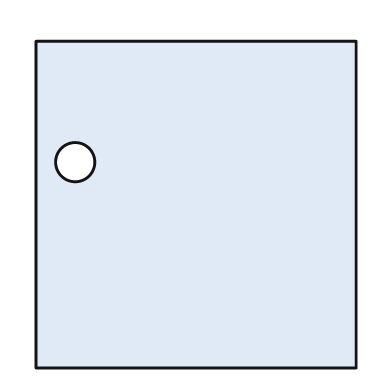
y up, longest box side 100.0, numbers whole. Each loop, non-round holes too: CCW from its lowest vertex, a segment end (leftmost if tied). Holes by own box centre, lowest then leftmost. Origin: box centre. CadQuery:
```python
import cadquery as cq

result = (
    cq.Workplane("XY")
    .moveTo(-49.0, -50.0)
    .lineTo(49.0, -50.0)
    .lineTo(49.0, 50.0)
    .lineTo(-49.0, 50.0)
    .close()
    .moveTo(-37.0, 13.0)
    .circle(6.0)
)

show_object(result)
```